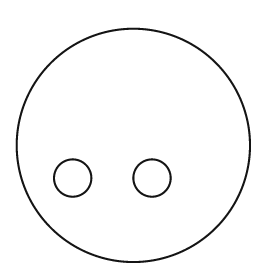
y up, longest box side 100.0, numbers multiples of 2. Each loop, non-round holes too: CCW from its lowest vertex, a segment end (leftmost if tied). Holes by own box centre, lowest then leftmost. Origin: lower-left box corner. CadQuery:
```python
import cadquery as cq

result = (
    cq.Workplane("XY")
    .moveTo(50.0, 50.0)
    .circle(50.0)
    .moveTo(24.0, 36.0)
    .circle(8.0)
    .moveTo(58.0, 36.0)
    .circle(8.0)
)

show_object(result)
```